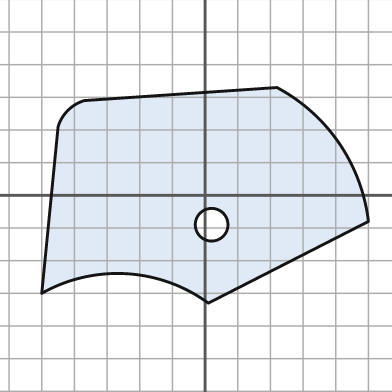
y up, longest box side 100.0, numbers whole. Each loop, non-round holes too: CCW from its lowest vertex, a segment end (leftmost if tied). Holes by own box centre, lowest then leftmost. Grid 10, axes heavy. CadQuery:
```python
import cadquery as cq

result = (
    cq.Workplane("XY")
    .moveTo(1.0, -33.0)
    .lineTo(50.0, -8.0)
    .threePointArc((41.0, 16.0), (22.0, 33.0))
    .lineTo(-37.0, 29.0)
    .threePointArc((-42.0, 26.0), (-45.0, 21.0))
    .lineTo(-50.0, -30.0)
    .threePointArc((-24.0, -24.0), (1.0, -33.0))
    .close()
    .moveTo(2.0, -9.0)
    .circle(5.0)
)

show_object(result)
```